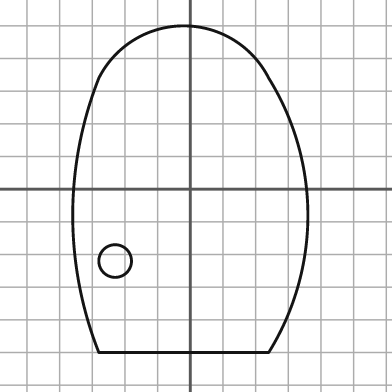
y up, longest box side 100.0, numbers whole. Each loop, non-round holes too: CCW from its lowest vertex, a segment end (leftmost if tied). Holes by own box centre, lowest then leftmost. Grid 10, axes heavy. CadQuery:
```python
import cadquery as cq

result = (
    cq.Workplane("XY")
    .moveTo(-28.0, -50.0)
    .lineTo(24.0, -50.0)
    .threePointArc((36.0, -8.0), (24.0, 34.0))
    .threePointArc((-2.0, 50.0), (-28.0, 34.0))
    .threePointArc((-36.0, -8.0), (-28.0, -50.0))
    .close()
    .moveTo(-23.0, -22.0)
    .circle(5.0)
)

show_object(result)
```